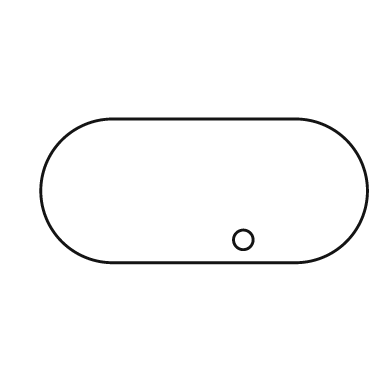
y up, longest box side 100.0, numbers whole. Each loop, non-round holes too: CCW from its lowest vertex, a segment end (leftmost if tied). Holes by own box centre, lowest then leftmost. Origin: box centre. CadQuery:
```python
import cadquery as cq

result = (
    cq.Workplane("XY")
    .moveTo(-28.0, -22.0)
    .lineTo(28.0, -22.0)
    .threePointArc((50.0, 0.0), (28.0, 22.0))
    .lineTo(-28.0, 22.0)
    .threePointArc((-50.0, 0.0), (-28.0, -22.0))
    .close()
    .moveTo(12.0, -15.0)
    .circle(3.0)
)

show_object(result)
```